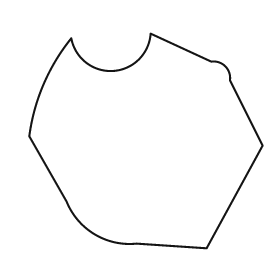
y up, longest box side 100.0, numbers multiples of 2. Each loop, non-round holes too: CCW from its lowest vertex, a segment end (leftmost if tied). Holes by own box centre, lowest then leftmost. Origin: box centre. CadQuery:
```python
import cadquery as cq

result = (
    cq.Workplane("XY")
    .moveTo(26.0, -46.0)
    .lineTo(50.0, -2.0)
    .lineTo(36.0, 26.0)
    .threePointArc((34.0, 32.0), (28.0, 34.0))
    .lineTo(2.0, 46.0)
    .threePointArc((-14.0, 30.0), (-32.0, 44.0))
    .threePointArc((-44.0, 24.0), (-50.0, 2.0))
    .lineTo(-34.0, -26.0)
    .threePointArc((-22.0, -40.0), (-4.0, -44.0))
    .close()
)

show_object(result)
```